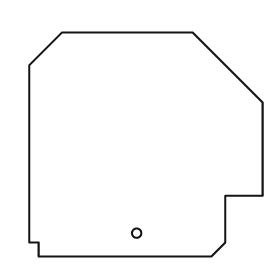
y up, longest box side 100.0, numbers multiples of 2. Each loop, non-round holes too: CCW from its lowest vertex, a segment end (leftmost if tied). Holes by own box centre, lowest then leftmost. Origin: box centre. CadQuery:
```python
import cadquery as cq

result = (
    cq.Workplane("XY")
    .moveTo(-46.0, -48.0)
    .lineTo(28.0, -48.0)
    .lineTo(34.0, -42.0)
    .lineTo(34.0, -22.0)
    .lineTo(50.0, -22.0)
    .lineTo(50.0, 18.0)
    .lineTo(20.0, 48.0)
    .lineTo(-36.0, 48.0)
    .lineTo(-50.0, 34.0)
    .lineTo(-50.0, -42.0)
    .lineTo(-46.0, -42.0)
    .close()
    .moveTo(-4.0, -38.0)
    .circle(2.0)
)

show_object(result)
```